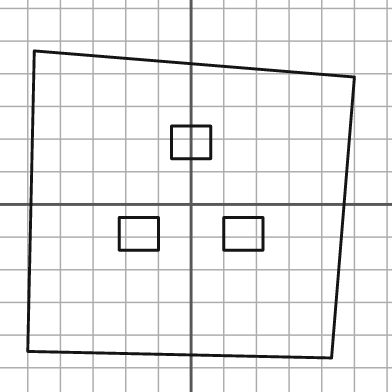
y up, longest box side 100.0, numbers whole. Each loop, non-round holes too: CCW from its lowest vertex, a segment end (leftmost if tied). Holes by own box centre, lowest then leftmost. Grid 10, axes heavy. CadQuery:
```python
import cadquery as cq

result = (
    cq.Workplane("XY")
    .moveTo(43.0, -47.0)
    .lineTo(50.0, 39.0)
    .lineTo(-48.0, 47.0)
    .lineTo(-50.0, -45.0)
    .close()
    .moveTo(-22.0, -14.0)
    .lineTo(-10.0, -14.0)
    .lineTo(-10.0, -4.0)
    .lineTo(-22.0, -4.0)
    .close()
    .moveTo(10.0, -14.0)
    .lineTo(22.0, -14.0)
    .lineTo(22.0, -4.0)
    .lineTo(10.0, -4.0)
    .close()
    .moveTo(-6.0, 14.0)
    .lineTo(6.0, 14.0)
    .lineTo(6.0, 24.0)
    .lineTo(-6.0, 24.0)
    .close()
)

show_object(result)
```